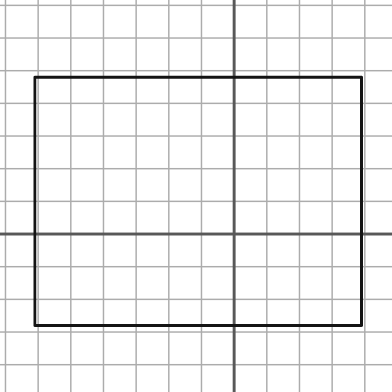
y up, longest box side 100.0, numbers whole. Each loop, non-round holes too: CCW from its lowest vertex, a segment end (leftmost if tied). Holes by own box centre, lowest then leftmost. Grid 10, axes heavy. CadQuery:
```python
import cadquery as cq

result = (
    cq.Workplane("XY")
    .moveTo(-61.0, -28.0)
    .lineTo(39.0, -28.0)
    .lineTo(39.0, 48.0)
    .lineTo(-61.0, 48.0)
    .close()
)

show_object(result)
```